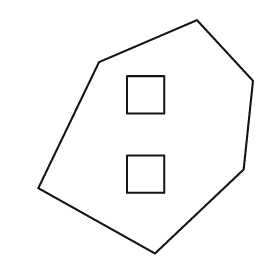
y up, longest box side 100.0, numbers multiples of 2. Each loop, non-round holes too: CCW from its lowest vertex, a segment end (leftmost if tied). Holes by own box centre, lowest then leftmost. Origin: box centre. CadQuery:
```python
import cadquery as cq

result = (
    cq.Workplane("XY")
    .moveTo(4.0, -50.0)
    .lineTo(42.0, -14.0)
    .lineTo(46.0, 24.0)
    .lineTo(22.0, 50.0)
    .lineTo(-20.0, 32.0)
    .lineTo(-46.0, -22.0)
    .close()
    .moveTo(-8.0, -24.0)
    .lineTo(8.0, -24.0)
    .lineTo(8.0, -8.0)
    .lineTo(-8.0, -8.0)
    .close()
    .moveTo(-8.0, 10.0)
    .lineTo(8.0, 10.0)
    .lineTo(8.0, 26.0)
    .lineTo(-8.0, 26.0)
    .close()
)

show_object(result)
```